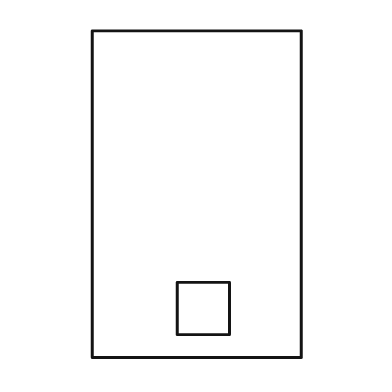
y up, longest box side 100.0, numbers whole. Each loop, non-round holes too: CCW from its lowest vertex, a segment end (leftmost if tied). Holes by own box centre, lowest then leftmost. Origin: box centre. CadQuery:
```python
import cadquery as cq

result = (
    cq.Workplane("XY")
    .moveTo(-32.0, -50.0)
    .lineTo(32.0, -50.0)
    .lineTo(32.0, 50.0)
    .lineTo(-32.0, 50.0)
    .close()
    .moveTo(-6.0, -43.0)
    .lineTo(10.0, -43.0)
    .lineTo(10.0, -27.0)
    .lineTo(-6.0, -27.0)
    .close()
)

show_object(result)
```